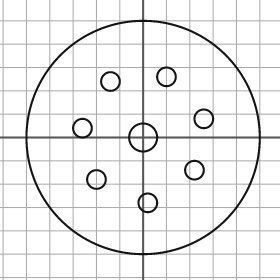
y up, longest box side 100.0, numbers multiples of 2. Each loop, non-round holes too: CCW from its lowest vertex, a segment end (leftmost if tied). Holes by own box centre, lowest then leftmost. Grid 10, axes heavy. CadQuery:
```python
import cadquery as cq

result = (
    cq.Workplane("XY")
    .moveTo(0.0, 0.0)
    .circle(50.0)
    .moveTo(2.0, -28.0)
    .circle(4.0)
    .moveTo(-20.0, -18.0)
    .circle(4.0)
    .moveTo(22.0, -14.0)
    .circle(4.0)
    .moveTo(0.0, 0.0)
    .circle(6.0)
    .moveTo(-26.0, 4.0)
    .circle(4.0)
    .moveTo(26.0, 8.0)
    .circle(4.0)
    .moveTo(-14.0, 24.0)
    .circle(4.0)
    .moveTo(10.0, 26.0)
    .circle(4.0)
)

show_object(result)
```